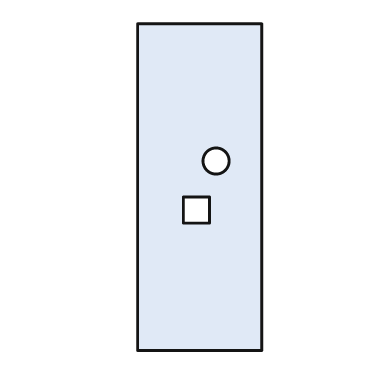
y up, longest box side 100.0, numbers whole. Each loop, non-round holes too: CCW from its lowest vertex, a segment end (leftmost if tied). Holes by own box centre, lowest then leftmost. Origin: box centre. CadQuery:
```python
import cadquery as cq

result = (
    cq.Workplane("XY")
    .moveTo(-19.0, -50.0)
    .lineTo(19.0, -50.0)
    .lineTo(19.0, 50.0)
    .lineTo(-19.0, 50.0)
    .close()
    .moveTo(-5.0, -11.0)
    .lineTo(3.0, -11.0)
    .lineTo(3.0, -3.0)
    .lineTo(-5.0, -3.0)
    .close()
    .moveTo(5.0, 8.0)
    .circle(4.0)
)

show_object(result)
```